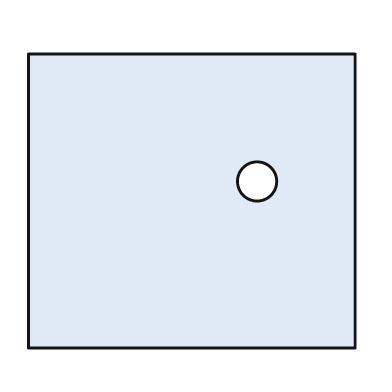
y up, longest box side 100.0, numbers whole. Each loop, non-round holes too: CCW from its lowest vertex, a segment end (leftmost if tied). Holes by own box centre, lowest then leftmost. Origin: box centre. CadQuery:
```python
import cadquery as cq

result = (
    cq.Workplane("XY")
    .moveTo(-50.0, -45.0)
    .lineTo(50.0, -45.0)
    .lineTo(50.0, 45.0)
    .lineTo(-50.0, 45.0)
    .close()
    .moveTo(20.0, 6.0)
    .circle(6.0)
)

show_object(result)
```